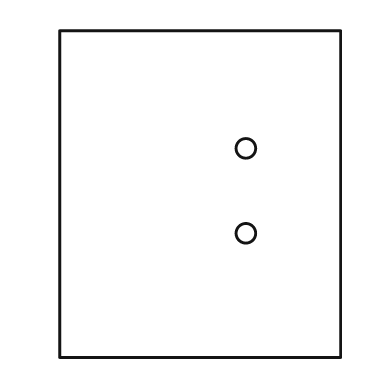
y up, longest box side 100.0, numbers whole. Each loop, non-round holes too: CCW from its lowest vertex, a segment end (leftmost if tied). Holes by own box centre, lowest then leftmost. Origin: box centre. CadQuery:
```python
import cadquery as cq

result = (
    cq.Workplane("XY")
    .moveTo(-43.0, -50.0)
    .lineTo(43.0, -50.0)
    .lineTo(43.0, 50.0)
    .lineTo(-43.0, 50.0)
    .close()
    .moveTo(14.0, -12.0)
    .circle(3.0)
    .moveTo(14.0, 14.0)
    .circle(3.0)
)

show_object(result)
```